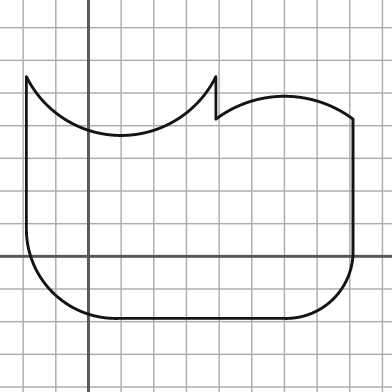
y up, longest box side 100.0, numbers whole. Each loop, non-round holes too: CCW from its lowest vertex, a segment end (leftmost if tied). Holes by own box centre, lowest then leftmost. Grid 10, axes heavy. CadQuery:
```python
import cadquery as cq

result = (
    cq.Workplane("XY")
    .moveTo(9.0, -19.0)
    .lineTo(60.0, -19.0)
    .threePointArc((75.0, -13.0), (81.0, 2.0))
    .lineTo(81.0, 42.0)
    .threePointArc((60.0, 49.0), (39.0, 42.0))
    .lineTo(39.0, 55.0)
    .threePointArc((10.0, 37.0), (-19.0, 55.0))
    .lineTo(-19.0, 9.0)
    .threePointArc((-11.0, -11.0), (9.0, -19.0))
    .close()
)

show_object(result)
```